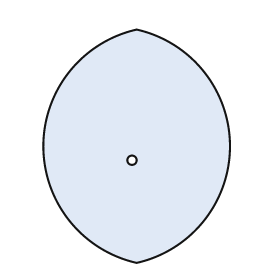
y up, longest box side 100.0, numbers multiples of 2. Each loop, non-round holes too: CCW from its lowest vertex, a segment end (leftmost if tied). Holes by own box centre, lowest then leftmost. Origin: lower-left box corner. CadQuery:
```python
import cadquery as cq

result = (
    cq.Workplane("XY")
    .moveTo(40.0, 0.0)
    .threePointArc((80.0, 50.0), (40.0, 100.0))
    .threePointArc((0.0, 50.0), (40.0, 0.0))
    .close()
    .moveTo(38.0, 44.0)
    .circle(2.0)
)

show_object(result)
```